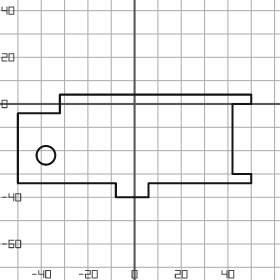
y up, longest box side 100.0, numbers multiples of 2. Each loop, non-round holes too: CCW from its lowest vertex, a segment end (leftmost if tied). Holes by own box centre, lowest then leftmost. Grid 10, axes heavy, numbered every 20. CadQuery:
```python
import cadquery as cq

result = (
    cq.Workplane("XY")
    .moveTo(-8.0, -40.0)
    .lineTo(6.0, -40.0)
    .lineTo(6.0, -34.0)
    .lineTo(50.0, -34.0)
    .lineTo(50.0, -30.0)
    .lineTo(42.0, -30.0)
    .lineTo(42.0, 0.0)
    .lineTo(50.0, 0.0)
    .lineTo(50.0, 4.0)
    .lineTo(-32.0, 4.0)
    .lineTo(-32.0, -4.0)
    .lineTo(-50.0, -4.0)
    .lineTo(-50.0, -34.0)
    .lineTo(-8.0, -34.0)
    .close()
    .moveTo(-38.0, -22.0)
    .circle(4.0)
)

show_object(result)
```